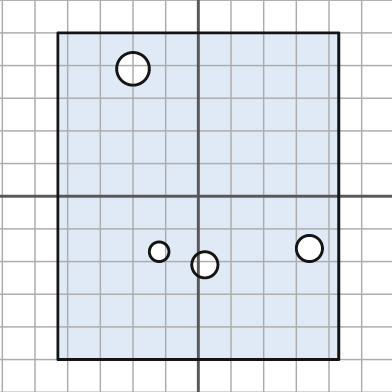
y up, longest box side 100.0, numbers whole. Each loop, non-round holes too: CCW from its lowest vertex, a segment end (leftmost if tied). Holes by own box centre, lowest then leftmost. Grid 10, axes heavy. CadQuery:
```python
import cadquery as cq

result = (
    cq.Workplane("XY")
    .moveTo(-43.0, -50.0)
    .lineTo(43.0, -50.0)
    .lineTo(43.0, 50.0)
    .lineTo(-43.0, 50.0)
    .close()
    .moveTo(2.0, -21.0)
    .circle(4.0)
    .moveTo(-12.0, -17.0)
    .circle(3.0)
    .moveTo(34.0, -16.0)
    .circle(4.0)
    .moveTo(-20.0, 39.0)
    .circle(5.0)
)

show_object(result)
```